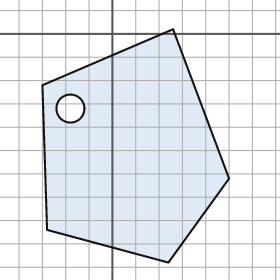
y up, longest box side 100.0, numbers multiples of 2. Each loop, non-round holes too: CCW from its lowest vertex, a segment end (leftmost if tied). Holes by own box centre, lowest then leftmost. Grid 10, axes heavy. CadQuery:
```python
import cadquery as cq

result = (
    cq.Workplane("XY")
    .moveTo(24.0, -98.0)
    .lineTo(50.0, -62.0)
    .lineTo(26.0, 2.0)
    .lineTo(-30.0, -22.0)
    .lineTo(-28.0, -84.0)
    .close()
    .moveTo(-18.0, -32.0)
    .circle(6.0)
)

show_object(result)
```